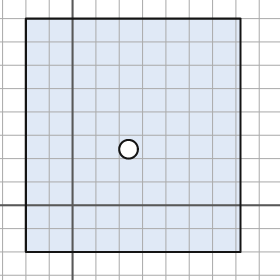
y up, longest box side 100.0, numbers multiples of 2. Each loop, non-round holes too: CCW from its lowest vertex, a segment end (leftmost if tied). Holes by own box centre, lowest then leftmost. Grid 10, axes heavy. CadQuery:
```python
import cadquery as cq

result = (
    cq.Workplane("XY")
    .moveTo(-20.0, -20.0)
    .lineTo(72.0, -20.0)
    .lineTo(72.0, 80.0)
    .lineTo(-20.0, 80.0)
    .close()
    .moveTo(24.0, 24.0)
    .circle(4.0)
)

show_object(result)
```